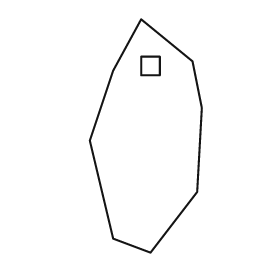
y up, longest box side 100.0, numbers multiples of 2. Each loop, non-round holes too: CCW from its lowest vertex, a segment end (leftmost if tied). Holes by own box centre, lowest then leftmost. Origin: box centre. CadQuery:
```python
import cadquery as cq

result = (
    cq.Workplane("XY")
    .moveTo(2.0, -50.0)
    .lineTo(22.0, -24.0)
    .lineTo(24.0, 12.0)
    .lineTo(20.0, 32.0)
    .lineTo(-2.0, 50.0)
    .lineTo(-14.0, 28.0)
    .lineTo(-24.0, -2.0)
    .lineTo(-14.0, -44.0)
    .close()
    .moveTo(-2.0, 26.0)
    .lineTo(6.0, 26.0)
    .lineTo(6.0, 34.0)
    .lineTo(-2.0, 34.0)
    .close()
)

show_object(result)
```